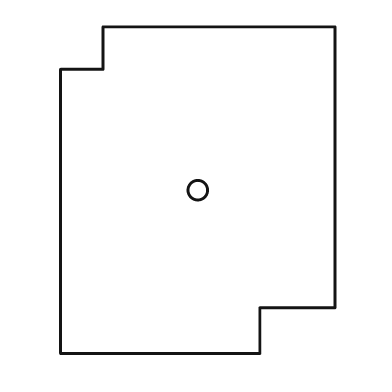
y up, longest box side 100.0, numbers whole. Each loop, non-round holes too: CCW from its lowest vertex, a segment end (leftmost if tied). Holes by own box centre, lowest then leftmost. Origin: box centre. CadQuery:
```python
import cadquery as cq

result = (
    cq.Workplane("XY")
    .moveTo(-42.0, -50.0)
    .lineTo(19.0, -50.0)
    .lineTo(19.0, -36.0)
    .lineTo(42.0, -36.0)
    .lineTo(42.0, 50.0)
    .lineTo(-29.0, 50.0)
    .lineTo(-29.0, 37.0)
    .lineTo(-42.0, 37.0)
    .close()
    .moveTo(0.0, 0.0)
    .circle(3.0)
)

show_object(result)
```